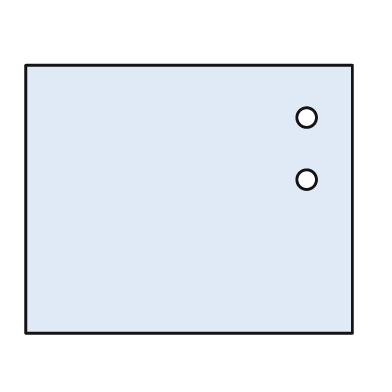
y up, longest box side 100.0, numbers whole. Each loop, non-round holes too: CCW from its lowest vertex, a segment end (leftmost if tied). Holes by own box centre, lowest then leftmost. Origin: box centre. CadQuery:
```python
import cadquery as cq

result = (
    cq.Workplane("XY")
    .moveTo(-50.0, -41.0)
    .lineTo(50.0, -41.0)
    .lineTo(50.0, 41.0)
    .lineTo(-50.0, 41.0)
    .close()
    .moveTo(36.0, 6.0)
    .circle(3.0)
    .moveTo(36.0, 25.0)
    .circle(3.0)
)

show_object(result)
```